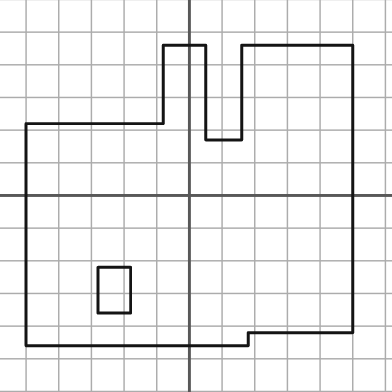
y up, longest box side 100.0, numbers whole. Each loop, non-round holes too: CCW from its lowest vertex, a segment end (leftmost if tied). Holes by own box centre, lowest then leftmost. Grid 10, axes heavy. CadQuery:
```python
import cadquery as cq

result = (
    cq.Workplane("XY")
    .moveTo(-50.0, -46.0)
    .lineTo(18.0, -46.0)
    .lineTo(18.0, -42.0)
    .lineTo(50.0, -42.0)
    .lineTo(50.0, 46.0)
    .lineTo(16.0, 46.0)
    .lineTo(16.0, 17.0)
    .lineTo(5.0, 17.0)
    .lineTo(5.0, 46.0)
    .lineTo(-8.0, 46.0)
    .lineTo(-8.0, 22.0)
    .lineTo(-50.0, 22.0)
    .close()
    .moveTo(-28.0, -36.0)
    .lineTo(-18.0, -36.0)
    .lineTo(-18.0, -22.0)
    .lineTo(-28.0, -22.0)
    .close()
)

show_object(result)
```